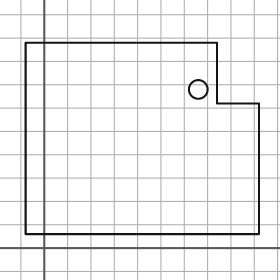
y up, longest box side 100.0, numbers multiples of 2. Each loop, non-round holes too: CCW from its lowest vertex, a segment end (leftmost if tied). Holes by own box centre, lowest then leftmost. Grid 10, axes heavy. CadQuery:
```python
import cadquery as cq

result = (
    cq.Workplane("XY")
    .moveTo(-8.0, 6.0)
    .lineTo(92.0, 6.0)
    .lineTo(92.0, 62.0)
    .lineTo(74.0, 62.0)
    .lineTo(74.0, 88.0)
    .lineTo(-8.0, 88.0)
    .close()
    .moveTo(66.0, 68.0)
    .circle(4.0)
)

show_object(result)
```